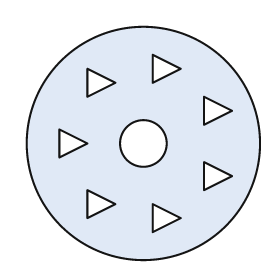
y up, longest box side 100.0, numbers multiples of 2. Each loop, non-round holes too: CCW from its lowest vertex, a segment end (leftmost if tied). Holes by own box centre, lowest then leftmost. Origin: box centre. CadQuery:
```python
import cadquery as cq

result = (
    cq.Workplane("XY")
    .moveTo(0.0, 0.0)
    .circle(50.0)
    .moveTo(4.0, -38.0)
    .lineTo(16.0, -32.0)
    .lineTo(4.0, -26.0)
    .close()
    .moveTo(-24.0, -32.0)
    .lineTo(-12.0, -26.0)
    .lineTo(-24.0, -20.0)
    .close()
    .moveTo(26.0, -20.0)
    .lineTo(38.0, -14.0)
    .lineTo(26.0, -8.0)
    .close()
    .moveTo(-36.0, -6.0)
    .lineTo(-24.0, 0.0)
    .lineTo(-36.0, 6.0)
    .close()
    .moveTo(0.0, 0.0)
    .circle(10.0)
    .moveTo(26.0, 8.0)
    .lineTo(38.0, 14.0)
    .lineTo(26.0, 20.0)
    .close()
    .moveTo(-24.0, 20.0)
    .lineTo(-12.0, 26.0)
    .lineTo(-24.0, 32.0)
    .close()
    .moveTo(4.0, 26.0)
    .lineTo(16.0, 32.0)
    .lineTo(4.0, 38.0)
    .close()
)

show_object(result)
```